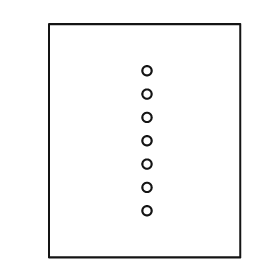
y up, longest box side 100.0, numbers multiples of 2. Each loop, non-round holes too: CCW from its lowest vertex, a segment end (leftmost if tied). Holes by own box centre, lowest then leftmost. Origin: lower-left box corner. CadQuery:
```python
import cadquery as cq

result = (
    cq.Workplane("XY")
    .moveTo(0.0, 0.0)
    .lineTo(82.0, 0.0)
    .lineTo(82.0, 100.0)
    .lineTo(0.0, 100.0)
    .close()
    .moveTo(42.0, 20.0)
    .circle(2.0)
    .moveTo(42.0, 30.0)
    .circle(2.0)
    .moveTo(42.0, 40.0)
    .circle(2.0)
    .moveTo(42.0, 50.0)
    .circle(2.0)
    .moveTo(42.0, 60.0)
    .circle(2.0)
    .moveTo(42.0, 70.0)
    .circle(2.0)
    .moveTo(42.0, 80.0)
    .circle(2.0)
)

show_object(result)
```